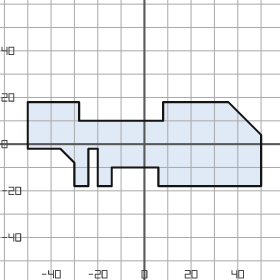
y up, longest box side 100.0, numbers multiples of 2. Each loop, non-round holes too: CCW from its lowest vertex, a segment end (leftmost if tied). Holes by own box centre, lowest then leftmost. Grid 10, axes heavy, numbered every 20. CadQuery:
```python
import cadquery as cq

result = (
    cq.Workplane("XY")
    .moveTo(-30.0, -18.0)
    .lineTo(-24.0, -18.0)
    .lineTo(-24.0, -2.0)
    .lineTo(-20.0, -2.0)
    .lineTo(-20.0, -18.0)
    .lineTo(-14.0, -18.0)
    .lineTo(-14.0, -10.0)
    .lineTo(6.0, -10.0)
    .lineTo(6.0, -18.0)
    .lineTo(50.0, -18.0)
    .lineTo(50.0, 4.0)
    .lineTo(36.0, 18.0)
    .lineTo(8.0, 18.0)
    .lineTo(8.0, 10.0)
    .lineTo(-28.0, 10.0)
    .lineTo(-28.0, 18.0)
    .lineTo(-50.0, 18.0)
    .lineTo(-50.0, -2.0)
    .lineTo(-36.0, -2.0)
    .lineTo(-30.0, -8.0)
    .close()
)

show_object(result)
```